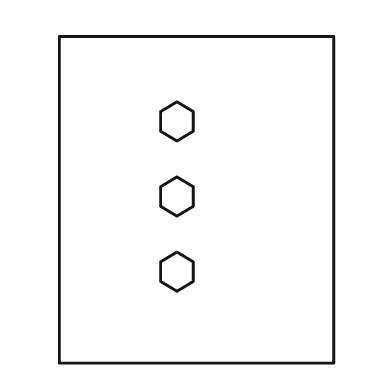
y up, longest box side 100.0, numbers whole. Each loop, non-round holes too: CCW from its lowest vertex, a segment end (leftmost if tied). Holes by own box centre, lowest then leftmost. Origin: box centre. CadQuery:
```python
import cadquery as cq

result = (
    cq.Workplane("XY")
    .moveTo(-42.0, -50.0)
    .lineTo(42.0, -50.0)
    .lineTo(42.0, 50.0)
    .lineTo(-42.0, 50.0)
    .close()
    .moveTo(-6.0, -28.0)
    .lineTo(-1.0, -25.0)
    .lineTo(-1.0, -19.0)
    .lineTo(-6.0, -16.0)
    .lineTo(-11.0, -19.0)
    .lineTo(-11.0, -25.0)
    .close()
    .moveTo(-6.0, -5.0)
    .lineTo(-1.0, -2.0)
    .lineTo(-1.0, 4.0)
    .lineTo(-6.0, 7.0)
    .lineTo(-11.0, 4.0)
    .lineTo(-11.0, -2.0)
    .close()
    .moveTo(-6.0, 18.0)
    .lineTo(-1.0, 21.0)
    .lineTo(-1.0, 27.0)
    .lineTo(-6.0, 30.0)
    .lineTo(-11.0, 27.0)
    .lineTo(-11.0, 21.0)
    .close()
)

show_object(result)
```